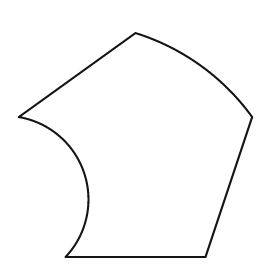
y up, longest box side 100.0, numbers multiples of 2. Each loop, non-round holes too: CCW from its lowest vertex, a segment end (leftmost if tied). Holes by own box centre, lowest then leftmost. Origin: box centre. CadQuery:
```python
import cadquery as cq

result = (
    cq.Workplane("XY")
    .moveTo(-30.0, -48.0)
    .lineTo(30.0, -48.0)
    .lineTo(50.0, 12.0)
    .threePointArc((28.0, 34.0), (0.0, 48.0))
    .lineTo(-50.0, 12.0)
    .threePointArc((-22.0, -12.0), (-30.0, -48.0))
    .close()
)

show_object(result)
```